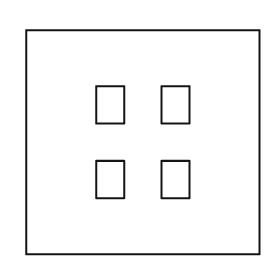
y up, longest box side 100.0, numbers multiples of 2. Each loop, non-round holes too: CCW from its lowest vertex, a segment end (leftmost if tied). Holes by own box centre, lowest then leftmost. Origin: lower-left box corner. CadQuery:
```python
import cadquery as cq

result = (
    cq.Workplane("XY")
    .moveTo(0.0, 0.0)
    .lineTo(100.0, 0.0)
    .lineTo(100.0, 96.0)
    .lineTo(0.0, 96.0)
    .close()
    .moveTo(30.0, 24.0)
    .lineTo(42.0, 24.0)
    .lineTo(42.0, 40.0)
    .lineTo(30.0, 40.0)
    .close()
    .moveTo(58.0, 24.0)
    .lineTo(70.0, 24.0)
    .lineTo(70.0, 40.0)
    .lineTo(58.0, 40.0)
    .close()
    .moveTo(30.0, 56.0)
    .lineTo(42.0, 56.0)
    .lineTo(42.0, 72.0)
    .lineTo(30.0, 72.0)
    .close()
    .moveTo(58.0, 56.0)
    .lineTo(70.0, 56.0)
    .lineTo(70.0, 72.0)
    .lineTo(58.0, 72.0)
    .close()
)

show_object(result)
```